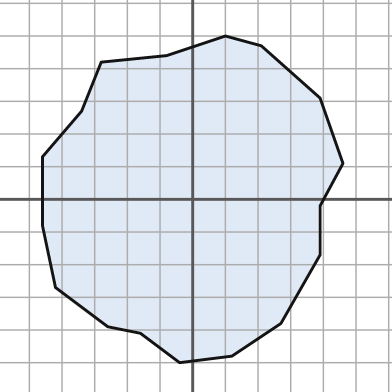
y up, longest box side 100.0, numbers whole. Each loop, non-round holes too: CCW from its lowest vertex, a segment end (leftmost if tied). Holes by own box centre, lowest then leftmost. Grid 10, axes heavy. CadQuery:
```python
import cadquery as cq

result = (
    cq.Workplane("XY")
    .moveTo(-4.0, -50.0)
    .lineTo(12.0, -48.0)
    .lineTo(27.0, -38.0)
    .lineTo(39.0, -17.0)
    .lineTo(39.0, -2.0)
    .lineTo(46.0, 11.0)
    .lineTo(39.0, 31.0)
    .lineTo(21.0, 47.0)
    .lineTo(10.0, 50.0)
    .lineTo(-8.0, 44.0)
    .lineTo(-28.0, 42.0)
    .lineTo(-34.0, 27.0)
    .lineTo(-46.0, 13.0)
    .lineTo(-46.0, -8.0)
    .lineTo(-42.0, -27.0)
    .lineTo(-26.0, -39.0)
    .lineTo(-16.0, -41.0)
    .close()
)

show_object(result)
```